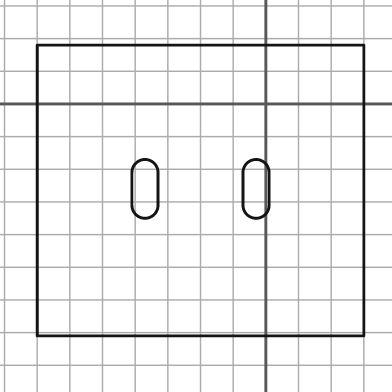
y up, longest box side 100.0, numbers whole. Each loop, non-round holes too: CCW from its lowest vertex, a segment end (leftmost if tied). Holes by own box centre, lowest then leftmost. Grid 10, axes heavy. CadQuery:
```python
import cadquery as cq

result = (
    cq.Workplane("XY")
    .moveTo(-70.0, -71.0)
    .lineTo(30.0, -71.0)
    .lineTo(30.0, 18.0)
    .lineTo(-70.0, 18.0)
    .close()
    .moveTo(-41.0, -31.0)
    .threePointArc((-37.0, -35.0), (-33.0, -31.0))
    .lineTo(-33.0, -21.0)
    .threePointArc((-37.0, -17.0), (-41.0, -21.0))
    .close()
    .moveTo(-7.0, -31.0)
    .threePointArc((-3.0, -35.0), (1.0, -31.0))
    .lineTo(1.0, -21.0)
    .threePointArc((-3.0, -17.0), (-7.0, -21.0))
    .close()
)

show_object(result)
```